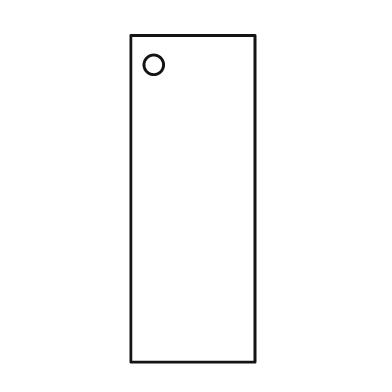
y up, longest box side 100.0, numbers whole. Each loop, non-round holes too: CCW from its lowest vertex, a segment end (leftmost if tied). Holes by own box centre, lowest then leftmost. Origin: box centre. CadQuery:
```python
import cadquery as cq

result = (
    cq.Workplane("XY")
    .moveTo(-19.0, -50.0)
    .lineTo(19.0, -50.0)
    .lineTo(19.0, 50.0)
    .lineTo(-19.0, 50.0)
    .close()
    .moveTo(-12.0, 41.0)
    .circle(3.0)
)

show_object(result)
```